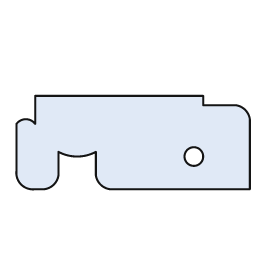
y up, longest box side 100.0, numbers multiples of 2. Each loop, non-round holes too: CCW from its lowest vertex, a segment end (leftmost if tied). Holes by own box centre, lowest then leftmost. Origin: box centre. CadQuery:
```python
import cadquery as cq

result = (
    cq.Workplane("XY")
    .moveTo(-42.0, -20.0)
    .lineTo(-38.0, -20.0)
    .threePointArc((-34.0, -18.0), (-32.0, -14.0))
    .lineTo(-32.0, -4.0)
    .threePointArc((-24.0, -6.0), (-16.0, -4.0))
    .lineTo(-16.0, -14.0)
    .threePointArc((-14.0, -18.0), (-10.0, -20.0))
    .lineTo(50.0, -20.0)
    .lineTo(50.0, 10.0)
    .threePointArc((48.0, 14.0), (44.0, 16.0))
    .lineTo(30.0, 16.0)
    .lineTo(30.0, 20.0)
    .lineTo(-42.0, 20.0)
    .lineTo(-42.0, 8.0)
    .threePointArc((-46.0, 10.0), (-50.0, 8.0))
    .lineTo(-50.0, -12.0)
    .threePointArc((-48.0, -18.0), (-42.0, -20.0))
    .close()
    .moveTo(26.0, -6.0)
    .circle(4.0)
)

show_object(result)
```